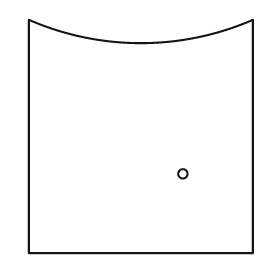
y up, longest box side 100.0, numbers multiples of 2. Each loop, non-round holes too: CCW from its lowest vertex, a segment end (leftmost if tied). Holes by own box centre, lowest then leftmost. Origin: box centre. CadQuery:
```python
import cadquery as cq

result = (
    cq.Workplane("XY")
    .moveTo(-48.0, -50.0)
    .lineTo(48.0, -50.0)
    .lineTo(48.0, 50.0)
    .threePointArc((0.0, 40.0), (-48.0, 50.0))
    .close()
    .moveTo(18.0, -16.0)
    .circle(2.0)
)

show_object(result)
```